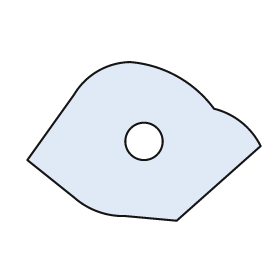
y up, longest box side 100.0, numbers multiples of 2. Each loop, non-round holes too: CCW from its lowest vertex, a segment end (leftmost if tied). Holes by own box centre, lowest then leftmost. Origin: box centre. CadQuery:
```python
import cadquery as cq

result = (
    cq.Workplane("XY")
    .moveTo(14.0, -34.0)
    .lineTo(50.0, -2.0)
    .threePointArc((42.0, 8.0), (30.0, 14.0))
    .threePointArc((14.0, 28.0), (-6.0, 34.0))
    .threePointArc((-20.0, 30.0), (-30.0, 20.0))
    .lineTo(-50.0, -8.0)
    .lineTo(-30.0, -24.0)
    .threePointArc((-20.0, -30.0), (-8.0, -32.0))
    .close()
    .moveTo(0.0, 0.0)
    .circle(8.0)
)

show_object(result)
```